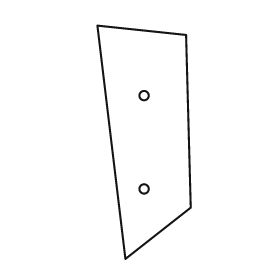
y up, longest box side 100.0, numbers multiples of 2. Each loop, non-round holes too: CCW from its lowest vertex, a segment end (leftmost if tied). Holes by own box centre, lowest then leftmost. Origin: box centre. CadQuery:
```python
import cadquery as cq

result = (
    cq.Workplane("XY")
    .moveTo(-8.0, -50.0)
    .lineTo(20.0, -28.0)
    .lineTo(18.0, 46.0)
    .lineTo(-20.0, 50.0)
    .close()
    .moveTo(0.0, -20.0)
    .circle(2.0)
    .moveTo(0.0, 20.0)
    .circle(2.0)
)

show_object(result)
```